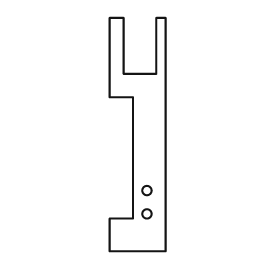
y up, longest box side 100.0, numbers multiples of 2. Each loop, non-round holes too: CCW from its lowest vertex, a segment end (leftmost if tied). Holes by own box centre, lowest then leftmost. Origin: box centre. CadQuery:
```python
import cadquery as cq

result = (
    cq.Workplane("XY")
    .moveTo(-12.0, -50.0)
    .lineTo(12.0, -50.0)
    .lineTo(12.0, 50.0)
    .lineTo(8.0, 50.0)
    .lineTo(8.0, 26.0)
    .lineTo(-6.0, 26.0)
    .lineTo(-6.0, 50.0)
    .lineTo(-12.0, 50.0)
    .lineTo(-12.0, 16.0)
    .lineTo(-2.0, 16.0)
    .lineTo(-2.0, -36.0)
    .lineTo(-12.0, -36.0)
    .close()
    .moveTo(4.0, -34.0)
    .circle(2.0)
    .moveTo(4.0, -24.0)
    .circle(2.0)
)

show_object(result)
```